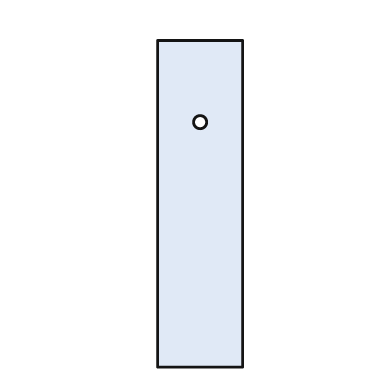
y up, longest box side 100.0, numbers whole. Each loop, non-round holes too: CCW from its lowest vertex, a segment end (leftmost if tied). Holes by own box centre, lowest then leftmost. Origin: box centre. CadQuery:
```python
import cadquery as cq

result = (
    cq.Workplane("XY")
    .moveTo(-13.0, -50.0)
    .lineTo(13.0, -50.0)
    .lineTo(13.0, 50.0)
    .lineTo(-13.0, 50.0)
    .close()
    .moveTo(0.0, 25.0)
    .circle(2.0)
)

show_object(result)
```